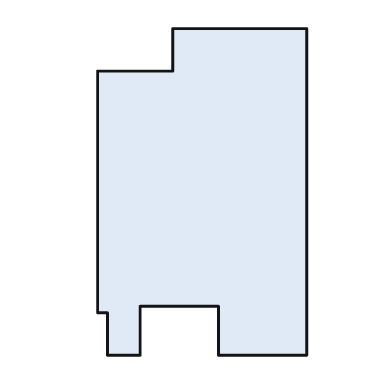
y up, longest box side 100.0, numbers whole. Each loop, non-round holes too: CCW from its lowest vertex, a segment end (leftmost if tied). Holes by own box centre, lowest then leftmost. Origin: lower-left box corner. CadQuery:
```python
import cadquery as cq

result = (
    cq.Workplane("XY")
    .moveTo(3.0, 0.0)
    .lineTo(13.0, 0.0)
    .lineTo(13.0, 15.0)
    .lineTo(37.0, 15.0)
    .lineTo(37.0, 0.0)
    .lineTo(64.0, 0.0)
    .lineTo(64.0, 100.0)
    .lineTo(23.0, 100.0)
    .lineTo(23.0, 87.0)
    .lineTo(0.0, 87.0)
    .lineTo(0.0, 13.0)
    .lineTo(3.0, 13.0)
    .close()
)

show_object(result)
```